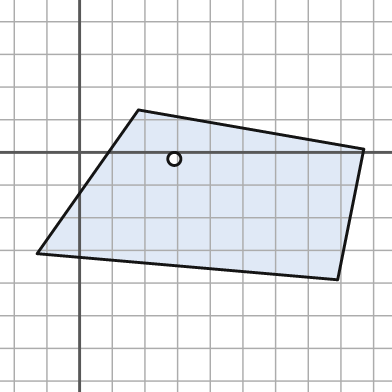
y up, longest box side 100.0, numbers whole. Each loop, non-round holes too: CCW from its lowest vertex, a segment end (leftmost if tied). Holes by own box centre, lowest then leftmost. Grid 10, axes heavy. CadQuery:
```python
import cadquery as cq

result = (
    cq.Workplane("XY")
    .moveTo(79.0, -39.0)
    .lineTo(87.0, 1.0)
    .lineTo(18.0, 13.0)
    .lineTo(-13.0, -31.0)
    .close()
    .moveTo(29.0, -2.0)
    .circle(2.0)
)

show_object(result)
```